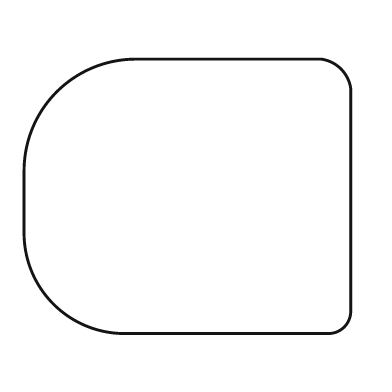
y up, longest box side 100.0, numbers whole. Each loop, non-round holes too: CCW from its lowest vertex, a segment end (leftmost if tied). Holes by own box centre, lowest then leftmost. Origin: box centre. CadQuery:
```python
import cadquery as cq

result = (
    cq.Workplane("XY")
    .moveTo(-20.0, -42.0)
    .lineTo(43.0, -42.0)
    .threePointArc((48.0, -40.0), (50.0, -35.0))
    .lineTo(50.0, 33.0)
    .threePointArc((47.0, 39.0), (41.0, 42.0))
    .lineTo(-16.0, 42.0)
    .threePointArc((-40.0, 32.0), (-50.0, 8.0))
    .lineTo(-50.0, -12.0)
    .threePointArc((-41.0, -33.0), (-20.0, -42.0))
    .close()
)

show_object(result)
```